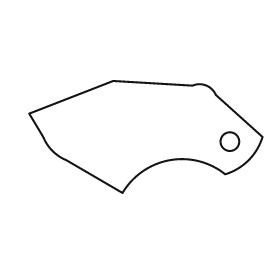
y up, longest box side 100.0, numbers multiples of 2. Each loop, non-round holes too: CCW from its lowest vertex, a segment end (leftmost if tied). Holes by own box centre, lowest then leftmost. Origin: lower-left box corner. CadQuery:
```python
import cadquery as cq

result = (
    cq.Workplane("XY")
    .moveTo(40.0, 0.0)
    .threePointArc((60.0, 14.0), (84.0, 8.0))
    .threePointArc((94.0, 14.0), (100.0, 24.0))
    .lineTo(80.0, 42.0)
    .threePointArc((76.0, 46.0), (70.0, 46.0))
    .lineTo(36.0, 48.0)
    .lineTo(0.0, 34.0)
    .lineTo(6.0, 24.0)
    .threePointArc((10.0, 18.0), (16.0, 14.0))
    .close()
    .moveTo(86.0, 22.0)
    .circle(4.0)
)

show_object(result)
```